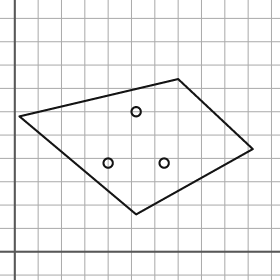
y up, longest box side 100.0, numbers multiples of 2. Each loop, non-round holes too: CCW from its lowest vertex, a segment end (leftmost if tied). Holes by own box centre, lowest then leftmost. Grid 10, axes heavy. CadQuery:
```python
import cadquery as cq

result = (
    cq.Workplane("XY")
    .moveTo(52.0, 16.0)
    .lineTo(102.0, 44.0)
    .lineTo(70.0, 74.0)
    .lineTo(2.0, 58.0)
    .close()
    .moveTo(40.0, 38.0)
    .circle(2.0)
    .moveTo(64.0, 38.0)
    .circle(2.0)
    .moveTo(52.0, 60.0)
    .circle(2.0)
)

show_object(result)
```